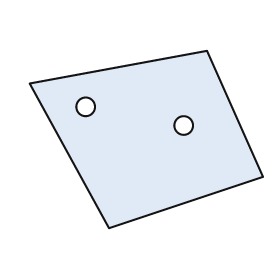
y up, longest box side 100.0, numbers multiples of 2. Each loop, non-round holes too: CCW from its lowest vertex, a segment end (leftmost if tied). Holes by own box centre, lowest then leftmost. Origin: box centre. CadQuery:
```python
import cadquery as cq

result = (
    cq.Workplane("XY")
    .moveTo(-16.0, -38.0)
    .lineTo(50.0, -16.0)
    .lineTo(26.0, 38.0)
    .lineTo(-50.0, 24.0)
    .close()
    .moveTo(16.0, 6.0)
    .circle(4.0)
    .moveTo(-26.0, 14.0)
    .circle(4.0)
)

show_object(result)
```